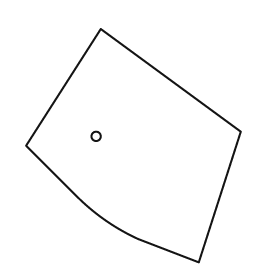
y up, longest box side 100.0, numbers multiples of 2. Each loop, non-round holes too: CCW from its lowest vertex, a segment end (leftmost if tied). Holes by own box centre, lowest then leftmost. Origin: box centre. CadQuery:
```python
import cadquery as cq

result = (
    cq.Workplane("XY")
    .moveTo(28.0, -50.0)
    .lineTo(46.0, 6.0)
    .lineTo(-14.0, 50.0)
    .lineTo(-46.0, 0.0)
    .lineTo(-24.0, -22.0)
    .threePointArc((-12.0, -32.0), (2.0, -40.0))
    .close()
    .moveTo(-16.0, 4.0)
    .circle(2.0)
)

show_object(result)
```